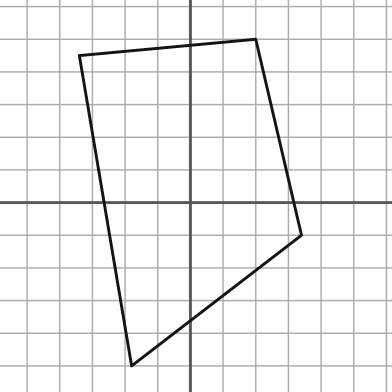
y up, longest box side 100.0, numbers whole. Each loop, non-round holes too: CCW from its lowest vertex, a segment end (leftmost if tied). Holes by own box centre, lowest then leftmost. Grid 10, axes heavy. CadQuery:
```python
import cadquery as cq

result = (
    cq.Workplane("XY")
    .moveTo(-18.0, -50.0)
    .lineTo(34.0, -10.0)
    .lineTo(20.0, 50.0)
    .lineTo(-34.0, 45.0)
    .close()
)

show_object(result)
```